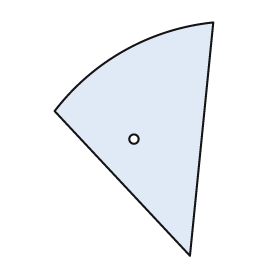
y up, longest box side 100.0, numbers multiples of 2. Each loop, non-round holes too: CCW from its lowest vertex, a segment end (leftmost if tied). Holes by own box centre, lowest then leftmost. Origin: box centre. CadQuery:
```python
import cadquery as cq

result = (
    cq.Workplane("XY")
    .moveTo(24.0, -50.0)
    .lineTo(34.0, 50.0)
    .threePointArc((-4.0, 38.0), (-34.0, 12.0))
    .close()
    .moveTo(0.0, 0.0)
    .circle(2.0)
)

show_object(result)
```